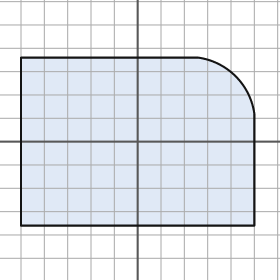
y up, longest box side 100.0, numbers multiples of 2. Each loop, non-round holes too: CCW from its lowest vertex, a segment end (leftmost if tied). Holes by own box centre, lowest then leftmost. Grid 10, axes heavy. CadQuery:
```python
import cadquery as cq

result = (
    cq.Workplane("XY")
    .moveTo(-50.0, -36.0)
    .lineTo(50.0, -36.0)
    .lineTo(50.0, 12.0)
    .threePointArc((42.0, 28.0), (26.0, 36.0))
    .lineTo(-50.0, 36.0)
    .close()
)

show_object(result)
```